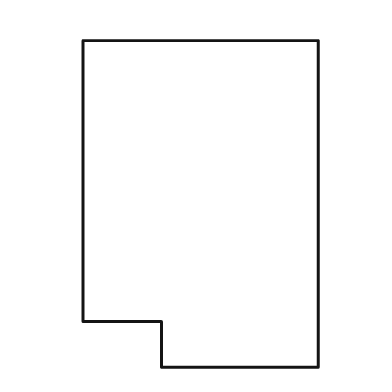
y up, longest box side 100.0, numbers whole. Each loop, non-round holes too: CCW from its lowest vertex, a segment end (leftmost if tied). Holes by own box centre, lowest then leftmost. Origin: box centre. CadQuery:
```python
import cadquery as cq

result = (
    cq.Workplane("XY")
    .moveTo(-12.0, -50.0)
    .lineTo(36.0, -50.0)
    .lineTo(36.0, 50.0)
    .lineTo(-36.0, 50.0)
    .lineTo(-36.0, -36.0)
    .lineTo(-12.0, -36.0)
    .close()
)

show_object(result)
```